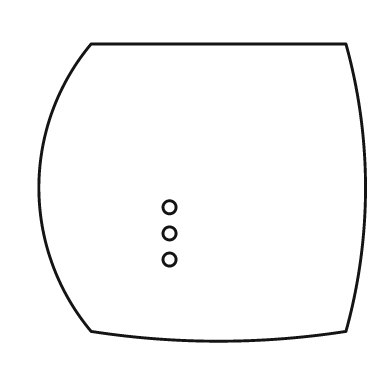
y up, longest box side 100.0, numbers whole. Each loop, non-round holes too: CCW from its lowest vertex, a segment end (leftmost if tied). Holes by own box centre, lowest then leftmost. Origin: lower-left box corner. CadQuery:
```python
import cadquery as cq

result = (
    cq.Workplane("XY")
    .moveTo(16.0, 3.0)
    .threePointArc((55.0, 0.0), (94.0, 3.0))
    .threePointArc((100.0, 47.0), (94.0, 91.0))
    .lineTo(16.0, 91.0)
    .threePointArc((0.0, 47.0), (16.0, 3.0))
    .close()
    .moveTo(40.0, 25.0)
    .circle(2.0)
    .moveTo(40.0, 33.0)
    .circle(2.0)
    .moveTo(40.0, 41.0)
    .circle(2.0)
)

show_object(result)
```